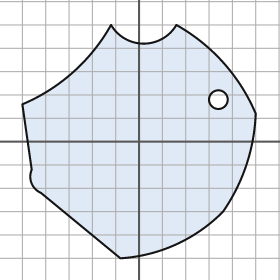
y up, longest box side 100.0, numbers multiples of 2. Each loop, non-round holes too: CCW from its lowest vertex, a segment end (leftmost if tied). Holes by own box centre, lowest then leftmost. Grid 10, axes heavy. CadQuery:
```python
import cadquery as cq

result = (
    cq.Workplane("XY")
    .moveTo(-8.0, -50.0)
    .threePointArc((16.0, -44.0), (36.0, -30.0))
    .threePointArc((46.0, -10.0), (50.0, 12.0))
    .threePointArc((36.0, 34.0), (16.0, 50.0))
    .threePointArc((2.0, 42.0), (-12.0, 50.0))
    .threePointArc((-28.0, 30.0), (-50.0, 16.0))
    .lineTo(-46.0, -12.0)
    .threePointArc((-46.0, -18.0), (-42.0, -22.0))
    .close()
    .moveTo(34.0, 18.0)
    .circle(4.0)
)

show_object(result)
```